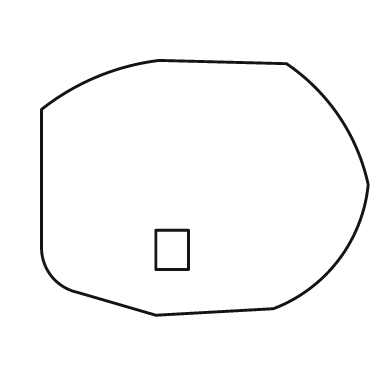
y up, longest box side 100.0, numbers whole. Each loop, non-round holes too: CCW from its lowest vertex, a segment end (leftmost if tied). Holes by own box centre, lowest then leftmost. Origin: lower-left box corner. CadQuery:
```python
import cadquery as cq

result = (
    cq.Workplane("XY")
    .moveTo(35.0, 0.0)
    .lineTo(71.0, 2.0)
    .threePointArc((91.0, 17.0), (100.0, 40.0))
    .threePointArc((91.0, 61.0), (75.0, 77.0))
    .lineTo(36.0, 78.0)
    .threePointArc((17.0, 73.0), (0.0, 63.0))
    .lineTo(0.0, 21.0)
    .threePointArc((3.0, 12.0), (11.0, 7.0))
    .close()
    .moveTo(35.0, 14.0)
    .lineTo(45.0, 14.0)
    .lineTo(45.0, 26.0)
    .lineTo(35.0, 26.0)
    .close()
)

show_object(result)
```